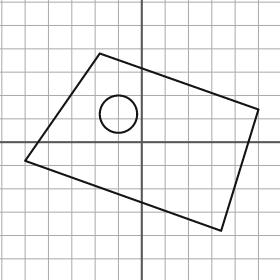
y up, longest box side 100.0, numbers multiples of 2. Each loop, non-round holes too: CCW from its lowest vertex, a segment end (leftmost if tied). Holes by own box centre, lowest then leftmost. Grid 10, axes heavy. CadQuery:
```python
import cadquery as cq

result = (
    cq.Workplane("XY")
    .moveTo(34.0, -38.0)
    .lineTo(50.0, 14.0)
    .lineTo(-18.0, 38.0)
    .lineTo(-50.0, -8.0)
    .close()
    .moveTo(-10.0, 12.0)
    .circle(8.0)
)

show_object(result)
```